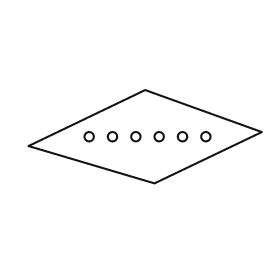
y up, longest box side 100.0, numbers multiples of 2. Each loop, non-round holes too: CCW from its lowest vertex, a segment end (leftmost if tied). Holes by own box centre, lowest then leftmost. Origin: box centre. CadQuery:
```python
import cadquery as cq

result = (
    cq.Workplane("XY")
    .moveTo(4.0, -20.0)
    .lineTo(50.0, 2.0)
    .lineTo(0.0, 20.0)
    .lineTo(-50.0, -4.0)
    .close()
    .moveTo(-24.0, 0.0)
    .circle(2.0)
    .moveTo(-14.0, 0.0)
    .circle(2.0)
    .moveTo(-4.0, 0.0)
    .circle(2.0)
    .moveTo(6.0, 0.0)
    .circle(2.0)
    .moveTo(16.0, 0.0)
    .circle(2.0)
    .moveTo(26.0, 0.0)
    .circle(2.0)
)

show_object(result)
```